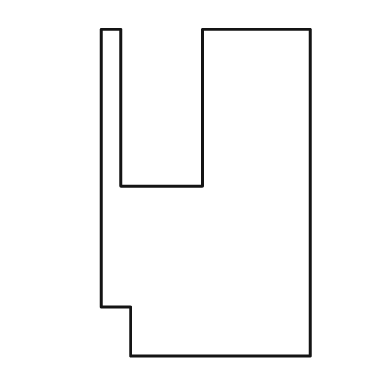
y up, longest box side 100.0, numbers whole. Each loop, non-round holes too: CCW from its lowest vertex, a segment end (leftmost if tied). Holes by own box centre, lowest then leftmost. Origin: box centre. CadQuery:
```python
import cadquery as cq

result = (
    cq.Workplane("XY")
    .moveTo(-23.0, -50.0)
    .lineTo(32.0, -50.0)
    .lineTo(32.0, 50.0)
    .lineTo(-1.0, 50.0)
    .lineTo(-1.0, 2.0)
    .lineTo(-26.0, 2.0)
    .lineTo(-26.0, 50.0)
    .lineTo(-32.0, 50.0)
    .lineTo(-32.0, -35.0)
    .lineTo(-23.0, -35.0)
    .close()
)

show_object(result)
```